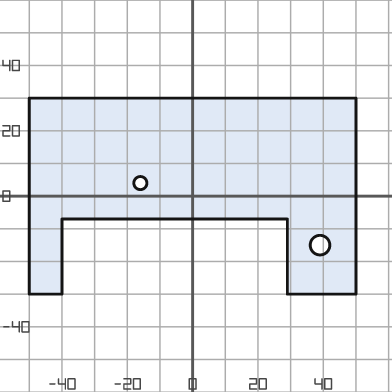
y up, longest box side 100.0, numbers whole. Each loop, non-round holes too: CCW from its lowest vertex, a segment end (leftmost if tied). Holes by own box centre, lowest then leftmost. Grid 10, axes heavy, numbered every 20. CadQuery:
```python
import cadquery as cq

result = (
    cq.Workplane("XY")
    .moveTo(-50.0, -30.0)
    .lineTo(-40.0, -30.0)
    .lineTo(-40.0, -7.0)
    .lineTo(29.0, -7.0)
    .lineTo(29.0, -30.0)
    .lineTo(50.0, -30.0)
    .lineTo(50.0, 30.0)
    .lineTo(-50.0, 30.0)
    .close()
    .moveTo(39.0, -15.0)
    .circle(3.0)
    .moveTo(-16.0, 4.0)
    .circle(2.0)
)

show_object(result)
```